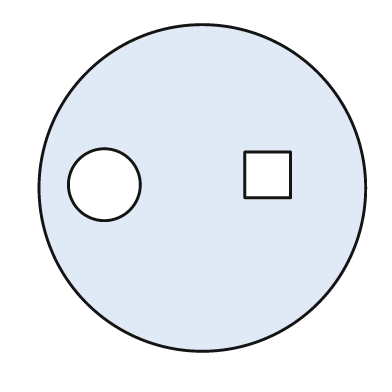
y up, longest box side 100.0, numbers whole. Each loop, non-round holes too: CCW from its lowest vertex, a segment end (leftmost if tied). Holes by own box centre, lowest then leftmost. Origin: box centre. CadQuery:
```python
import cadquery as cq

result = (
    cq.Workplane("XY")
    .moveTo(0.0, 0.0)
    .circle(50.0)
    .moveTo(-30.0, 1.0)
    .circle(11.0)
    .moveTo(13.0, -3.0)
    .lineTo(27.0, -3.0)
    .lineTo(27.0, 11.0)
    .lineTo(13.0, 11.0)
    .close()
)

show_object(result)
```